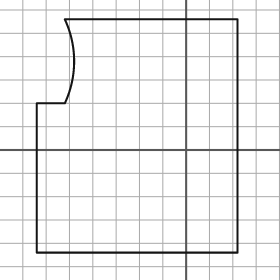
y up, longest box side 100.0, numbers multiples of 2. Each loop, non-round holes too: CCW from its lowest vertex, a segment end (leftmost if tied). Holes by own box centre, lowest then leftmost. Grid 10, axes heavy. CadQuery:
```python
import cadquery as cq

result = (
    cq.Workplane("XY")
    .moveTo(-64.0, -44.0)
    .lineTo(22.0, -44.0)
    .lineTo(22.0, 56.0)
    .lineTo(-52.0, 56.0)
    .threePointArc((-48.0, 38.0), (-52.0, 20.0))
    .lineTo(-64.0, 20.0)
    .close()
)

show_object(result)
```